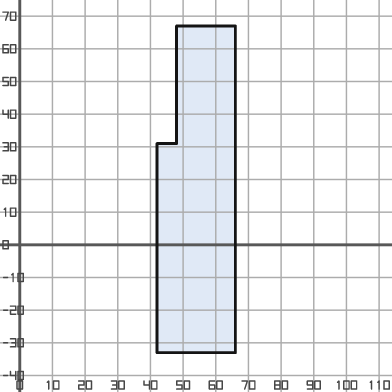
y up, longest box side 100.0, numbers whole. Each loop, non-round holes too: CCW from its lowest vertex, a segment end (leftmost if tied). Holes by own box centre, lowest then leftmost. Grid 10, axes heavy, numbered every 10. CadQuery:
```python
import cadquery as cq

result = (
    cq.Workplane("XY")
    .moveTo(42.0, -33.0)
    .lineTo(66.0, -33.0)
    .lineTo(66.0, 67.0)
    .lineTo(48.0, 67.0)
    .lineTo(48.0, 31.0)
    .lineTo(42.0, 31.0)
    .close()
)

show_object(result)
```